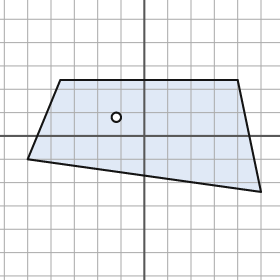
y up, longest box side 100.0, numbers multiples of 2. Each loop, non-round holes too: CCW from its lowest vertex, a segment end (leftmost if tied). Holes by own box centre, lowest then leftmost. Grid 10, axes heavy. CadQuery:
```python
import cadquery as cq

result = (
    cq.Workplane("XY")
    .moveTo(50.0, -24.0)
    .lineTo(40.0, 24.0)
    .lineTo(-36.0, 24.0)
    .lineTo(-50.0, -10.0)
    .close()
    .moveTo(-12.0, 8.0)
    .circle(2.0)
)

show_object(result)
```